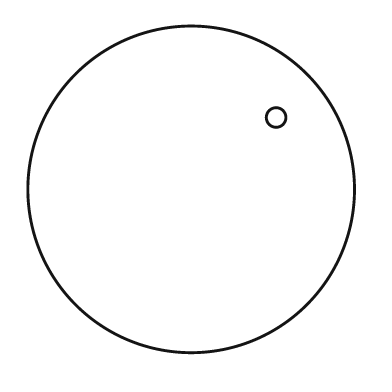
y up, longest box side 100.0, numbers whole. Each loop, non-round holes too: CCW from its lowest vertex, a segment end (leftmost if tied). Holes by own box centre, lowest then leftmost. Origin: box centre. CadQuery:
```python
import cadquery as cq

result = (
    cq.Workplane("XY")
    .moveTo(0.0, 0.0)
    .circle(50.0)
    .moveTo(26.0, 22.0)
    .circle(3.0)
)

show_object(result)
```